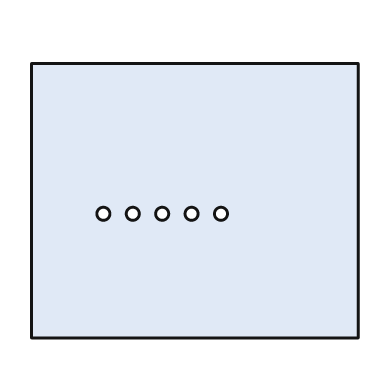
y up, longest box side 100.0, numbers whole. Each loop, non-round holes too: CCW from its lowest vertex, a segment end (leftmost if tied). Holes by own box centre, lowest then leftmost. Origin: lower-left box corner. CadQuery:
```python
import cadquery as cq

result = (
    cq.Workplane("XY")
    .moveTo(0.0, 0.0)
    .lineTo(100.0, 0.0)
    .lineTo(100.0, 84.0)
    .lineTo(0.0, 84.0)
    .close()
    .moveTo(22.0, 38.0)
    .circle(2.0)
    .moveTo(31.0, 38.0)
    .circle(2.0)
    .moveTo(40.0, 38.0)
    .circle(2.0)
    .moveTo(49.0, 38.0)
    .circle(2.0)
    .moveTo(58.0, 38.0)
    .circle(2.0)
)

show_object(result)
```